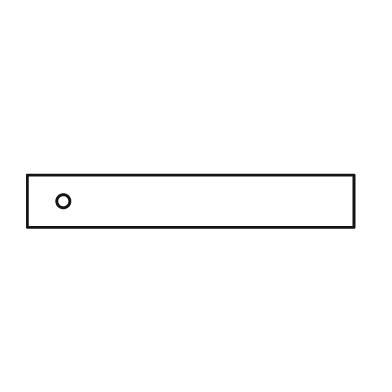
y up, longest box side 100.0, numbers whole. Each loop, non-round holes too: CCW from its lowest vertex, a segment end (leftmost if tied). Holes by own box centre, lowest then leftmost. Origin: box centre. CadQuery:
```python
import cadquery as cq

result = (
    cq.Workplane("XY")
    .moveTo(-50.0, -8.0)
    .lineTo(50.0, -8.0)
    .lineTo(50.0, 8.0)
    .lineTo(-50.0, 8.0)
    .close()
    .moveTo(-39.0, 0.0)
    .circle(2.0)
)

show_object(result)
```